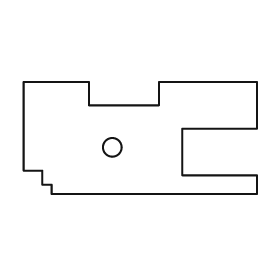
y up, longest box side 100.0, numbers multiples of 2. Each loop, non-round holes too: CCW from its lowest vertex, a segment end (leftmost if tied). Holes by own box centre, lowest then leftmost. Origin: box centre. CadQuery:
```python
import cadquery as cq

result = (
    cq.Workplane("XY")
    .moveTo(-38.0, -24.0)
    .lineTo(50.0, -24.0)
    .lineTo(50.0, -16.0)
    .lineTo(18.0, -16.0)
    .lineTo(18.0, 4.0)
    .lineTo(50.0, 4.0)
    .lineTo(50.0, 24.0)
    .lineTo(8.0, 24.0)
    .lineTo(8.0, 14.0)
    .lineTo(-22.0, 14.0)
    .lineTo(-22.0, 24.0)
    .lineTo(-50.0, 24.0)
    .lineTo(-50.0, -14.0)
    .lineTo(-42.0, -14.0)
    .lineTo(-42.0, -20.0)
    .lineTo(-38.0, -20.0)
    .close()
    .moveTo(-12.0, -4.0)
    .circle(4.0)
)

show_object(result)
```